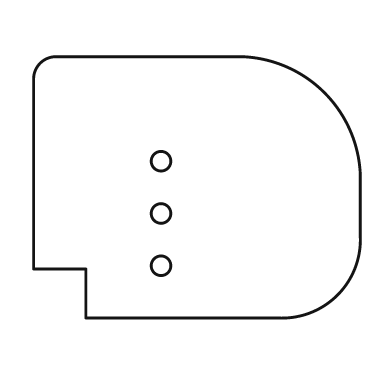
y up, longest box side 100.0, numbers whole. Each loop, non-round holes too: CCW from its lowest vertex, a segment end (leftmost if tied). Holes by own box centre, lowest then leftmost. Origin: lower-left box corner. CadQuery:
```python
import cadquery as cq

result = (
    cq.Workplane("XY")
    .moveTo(16.0, 0.0)
    .lineTo(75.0, 0.0)
    .threePointArc((93.0, 7.0), (100.0, 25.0))
    .lineTo(100.0, 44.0)
    .threePointArc((89.0, 69.0), (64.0, 80.0))
    .lineTo(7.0, 80.0)
    .threePointArc((2.0, 78.0), (0.0, 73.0))
    .lineTo(0.0, 15.0)
    .lineTo(16.0, 15.0)
    .close()
    .moveTo(39.0, 16.0)
    .circle(3.0)
    .moveTo(39.0, 32.0)
    .circle(3.0)
    .moveTo(39.0, 48.0)
    .circle(3.0)
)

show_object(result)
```